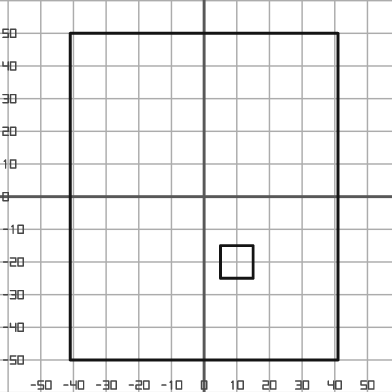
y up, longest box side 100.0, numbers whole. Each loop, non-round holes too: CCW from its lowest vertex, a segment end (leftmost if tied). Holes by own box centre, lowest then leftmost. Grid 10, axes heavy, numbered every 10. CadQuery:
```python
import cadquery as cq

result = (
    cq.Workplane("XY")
    .moveTo(-41.0, -50.0)
    .lineTo(41.0, -50.0)
    .lineTo(41.0, 50.0)
    .lineTo(-41.0, 50.0)
    .close()
    .moveTo(5.0, -25.0)
    .lineTo(15.0, -25.0)
    .lineTo(15.0, -15.0)
    .lineTo(5.0, -15.0)
    .close()
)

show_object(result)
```